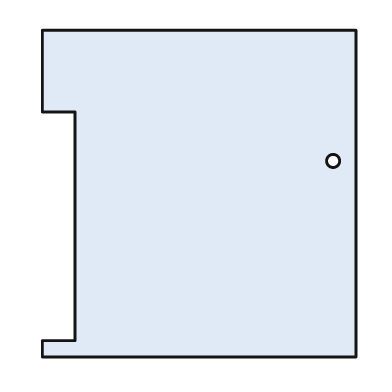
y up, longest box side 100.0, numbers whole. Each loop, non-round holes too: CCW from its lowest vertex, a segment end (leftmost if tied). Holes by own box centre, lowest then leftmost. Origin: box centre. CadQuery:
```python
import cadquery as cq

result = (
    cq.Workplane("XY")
    .moveTo(-48.0, -50.0)
    .lineTo(48.0, -50.0)
    .lineTo(48.0, 50.0)
    .lineTo(-48.0, 50.0)
    .lineTo(-48.0, 25.0)
    .lineTo(-38.0, 25.0)
    .lineTo(-38.0, -45.0)
    .lineTo(-48.0, -45.0)
    .close()
    .moveTo(41.0, 10.0)
    .circle(2.0)
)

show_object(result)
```